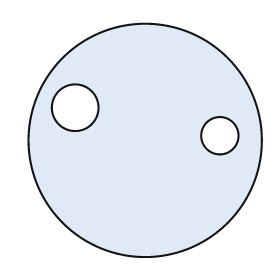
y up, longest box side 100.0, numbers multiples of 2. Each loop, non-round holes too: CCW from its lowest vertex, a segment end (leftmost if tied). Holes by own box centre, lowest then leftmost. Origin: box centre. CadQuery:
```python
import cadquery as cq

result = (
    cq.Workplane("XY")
    .moveTo(0.0, 0.0)
    .circle(50.0)
    .moveTo(32.0, 2.0)
    .circle(8.0)
    .moveTo(-30.0, 14.0)
    .circle(10.0)
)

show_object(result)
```